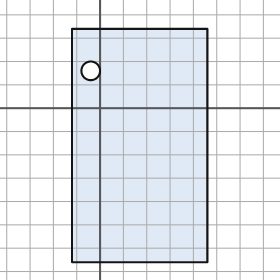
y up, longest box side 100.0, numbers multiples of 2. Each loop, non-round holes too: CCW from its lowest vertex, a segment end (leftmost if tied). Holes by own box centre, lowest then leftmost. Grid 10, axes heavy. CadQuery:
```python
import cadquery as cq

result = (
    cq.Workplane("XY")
    .moveTo(-12.0, -66.0)
    .lineTo(46.0, -66.0)
    .lineTo(46.0, 34.0)
    .lineTo(-12.0, 34.0)
    .close()
    .moveTo(-4.0, 16.0)
    .circle(4.0)
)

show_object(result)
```